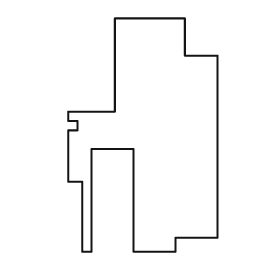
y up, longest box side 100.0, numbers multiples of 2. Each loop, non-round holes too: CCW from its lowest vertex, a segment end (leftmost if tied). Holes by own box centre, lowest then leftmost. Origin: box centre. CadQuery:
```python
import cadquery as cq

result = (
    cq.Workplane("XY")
    .moveTo(-26.0, -50.0)
    .lineTo(-22.0, -50.0)
    .lineTo(-22.0, -6.0)
    .lineTo(-4.0, -6.0)
    .lineTo(-4.0, -50.0)
    .lineTo(14.0, -50.0)
    .lineTo(14.0, -44.0)
    .lineTo(32.0, -44.0)
    .lineTo(32.0, 34.0)
    .lineTo(18.0, 34.0)
    .lineTo(18.0, 50.0)
    .lineTo(-12.0, 50.0)
    .lineTo(-12.0, 10.0)
    .lineTo(-32.0, 10.0)
    .lineTo(-32.0, 6.0)
    .lineTo(-28.0, 6.0)
    .lineTo(-28.0, 2.0)
    .lineTo(-32.0, 2.0)
    .lineTo(-32.0, -20.0)
    .lineTo(-26.0, -20.0)
    .close()
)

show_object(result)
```